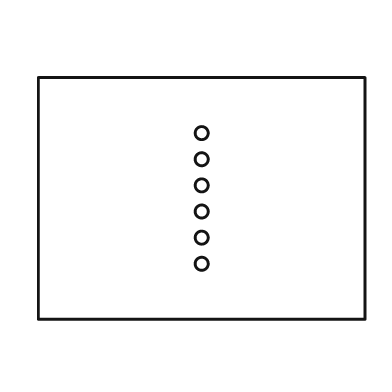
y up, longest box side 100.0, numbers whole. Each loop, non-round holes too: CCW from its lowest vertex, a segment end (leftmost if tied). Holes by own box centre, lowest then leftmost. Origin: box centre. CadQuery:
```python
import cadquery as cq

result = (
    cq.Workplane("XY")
    .moveTo(-50.0, -37.0)
    .lineTo(50.0, -37.0)
    .lineTo(50.0, 37.0)
    .lineTo(-50.0, 37.0)
    .close()
    .moveTo(0.0, -20.0)
    .circle(2.0)
    .moveTo(0.0, -12.0)
    .circle(2.0)
    .moveTo(0.0, -4.0)
    .circle(2.0)
    .moveTo(0.0, 4.0)
    .circle(2.0)
    .moveTo(0.0, 12.0)
    .circle(2.0)
    .moveTo(0.0, 20.0)
    .circle(2.0)
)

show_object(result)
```